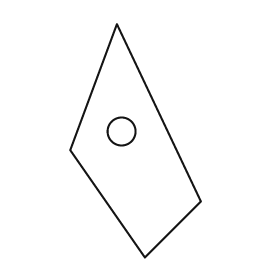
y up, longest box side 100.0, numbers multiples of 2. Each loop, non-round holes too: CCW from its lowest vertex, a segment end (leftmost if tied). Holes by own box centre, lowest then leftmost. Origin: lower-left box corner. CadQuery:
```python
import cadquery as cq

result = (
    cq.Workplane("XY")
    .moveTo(32.0, 0.0)
    .lineTo(56.0, 24.0)
    .lineTo(20.0, 100.0)
    .lineTo(0.0, 46.0)
    .close()
    .moveTo(22.0, 54.0)
    .circle(6.0)
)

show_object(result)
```